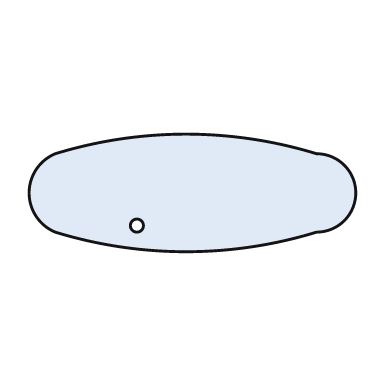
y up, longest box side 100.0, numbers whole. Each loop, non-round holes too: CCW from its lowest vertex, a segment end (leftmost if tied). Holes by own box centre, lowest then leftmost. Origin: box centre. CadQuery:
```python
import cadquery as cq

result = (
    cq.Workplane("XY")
    .moveTo(-42.0, -12.0)
    .threePointArc((-2.0, -18.0), (38.0, -12.0))
    .threePointArc((50.0, 0.0), (38.0, 12.0))
    .threePointArc((-2.0, 18.0), (-42.0, 12.0))
    .threePointArc((-50.0, 0.0), (-42.0, -12.0))
    .close()
    .moveTo(-17.0, -10.0)
    .circle(2.0)
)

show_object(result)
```